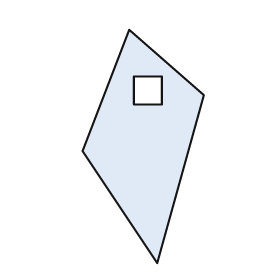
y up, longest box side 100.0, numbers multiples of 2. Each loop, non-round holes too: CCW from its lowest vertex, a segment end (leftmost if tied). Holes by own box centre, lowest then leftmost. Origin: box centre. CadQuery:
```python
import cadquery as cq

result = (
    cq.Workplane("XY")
    .moveTo(6.0, -50.0)
    .lineTo(26.0, 22.0)
    .lineTo(-6.0, 50.0)
    .lineTo(-26.0, -2.0)
    .close()
    .moveTo(-4.0, 18.0)
    .lineTo(8.0, 18.0)
    .lineTo(8.0, 30.0)
    .lineTo(-4.0, 30.0)
    .close()
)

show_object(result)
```